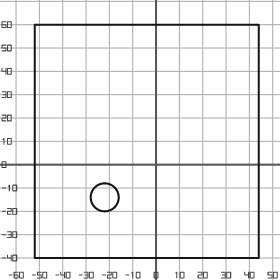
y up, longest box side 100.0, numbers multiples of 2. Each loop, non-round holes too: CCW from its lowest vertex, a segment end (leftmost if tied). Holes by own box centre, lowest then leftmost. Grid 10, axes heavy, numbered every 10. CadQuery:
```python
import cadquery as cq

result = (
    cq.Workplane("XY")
    .moveTo(-52.0, -40.0)
    .lineTo(44.0, -40.0)
    .lineTo(44.0, 60.0)
    .lineTo(-52.0, 60.0)
    .close()
    .moveTo(-22.0, -14.0)
    .circle(6.0)
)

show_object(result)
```